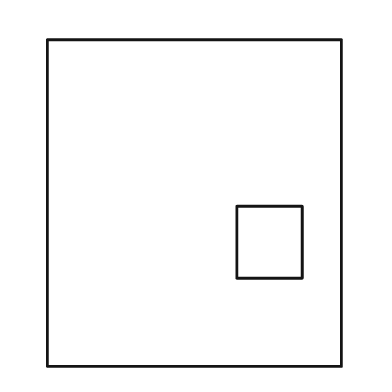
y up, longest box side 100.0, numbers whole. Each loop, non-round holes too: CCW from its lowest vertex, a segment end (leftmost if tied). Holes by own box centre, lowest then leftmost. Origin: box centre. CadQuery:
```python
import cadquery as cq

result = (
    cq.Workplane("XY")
    .moveTo(-45.0, -50.0)
    .lineTo(45.0, -50.0)
    .lineTo(45.0, 50.0)
    .lineTo(-45.0, 50.0)
    .close()
    .moveTo(13.0, -23.0)
    .lineTo(33.0, -23.0)
    .lineTo(33.0, -1.0)
    .lineTo(13.0, -1.0)
    .close()
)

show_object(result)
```